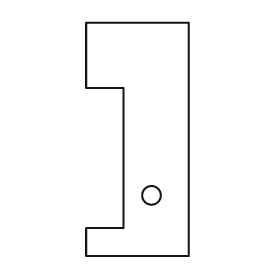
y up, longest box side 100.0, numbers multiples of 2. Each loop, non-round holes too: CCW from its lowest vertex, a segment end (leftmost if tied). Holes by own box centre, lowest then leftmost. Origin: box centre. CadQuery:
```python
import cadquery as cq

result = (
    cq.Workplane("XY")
    .moveTo(-22.0, -50.0)
    .lineTo(22.0, -50.0)
    .lineTo(22.0, 50.0)
    .lineTo(-22.0, 50.0)
    .lineTo(-22.0, 22.0)
    .lineTo(-6.0, 22.0)
    .lineTo(-6.0, -38.0)
    .lineTo(-22.0, -38.0)
    .close()
    .moveTo(6.0, -24.0)
    .circle(4.0)
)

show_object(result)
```